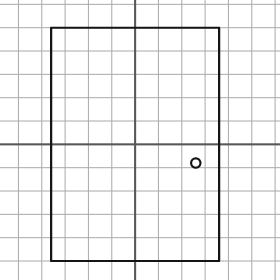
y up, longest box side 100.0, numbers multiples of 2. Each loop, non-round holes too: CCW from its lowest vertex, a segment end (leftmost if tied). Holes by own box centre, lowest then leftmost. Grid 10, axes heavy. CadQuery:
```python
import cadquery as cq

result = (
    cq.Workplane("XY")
    .moveTo(-36.0, -50.0)
    .lineTo(36.0, -50.0)
    .lineTo(36.0, 50.0)
    .lineTo(-36.0, 50.0)
    .close()
    .moveTo(26.0, -8.0)
    .circle(2.0)
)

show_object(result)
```